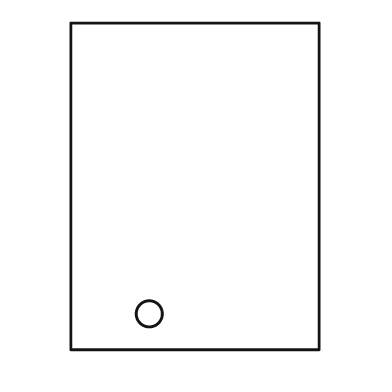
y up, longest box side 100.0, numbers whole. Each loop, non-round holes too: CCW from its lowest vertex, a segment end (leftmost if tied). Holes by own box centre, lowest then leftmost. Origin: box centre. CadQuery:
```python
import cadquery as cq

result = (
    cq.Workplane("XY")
    .moveTo(-38.0, -50.0)
    .lineTo(38.0, -50.0)
    .lineTo(38.0, 50.0)
    .lineTo(-38.0, 50.0)
    .close()
    .moveTo(-14.0, -39.0)
    .circle(4.0)
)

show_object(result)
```